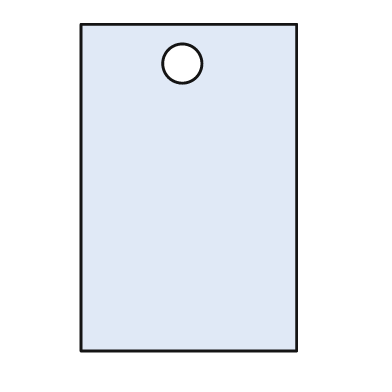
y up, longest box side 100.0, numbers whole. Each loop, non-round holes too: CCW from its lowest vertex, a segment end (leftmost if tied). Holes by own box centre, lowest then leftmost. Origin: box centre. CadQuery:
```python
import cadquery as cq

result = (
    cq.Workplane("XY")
    .moveTo(-33.0, -50.0)
    .lineTo(33.0, -50.0)
    .lineTo(33.0, 50.0)
    .lineTo(-33.0, 50.0)
    .close()
    .moveTo(-2.0, 38.0)
    .circle(6.0)
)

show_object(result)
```